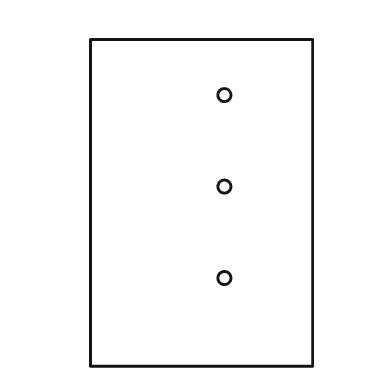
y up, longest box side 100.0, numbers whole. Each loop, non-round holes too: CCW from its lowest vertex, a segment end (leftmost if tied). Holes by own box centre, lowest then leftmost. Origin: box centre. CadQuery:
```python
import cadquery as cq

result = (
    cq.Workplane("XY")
    .moveTo(-34.0, -50.0)
    .lineTo(34.0, -50.0)
    .lineTo(34.0, 50.0)
    .lineTo(-34.0, 50.0)
    .close()
    .moveTo(7.0, -23.0)
    .circle(2.0)
    .moveTo(7.0, 5.0)
    .circle(2.0)
    .moveTo(7.0, 33.0)
    .circle(2.0)
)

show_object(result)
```